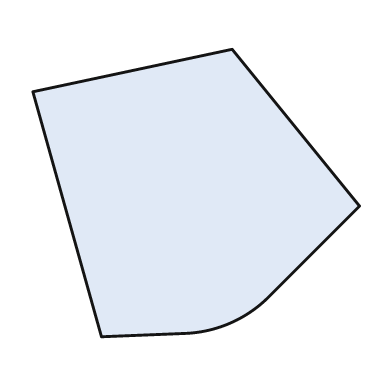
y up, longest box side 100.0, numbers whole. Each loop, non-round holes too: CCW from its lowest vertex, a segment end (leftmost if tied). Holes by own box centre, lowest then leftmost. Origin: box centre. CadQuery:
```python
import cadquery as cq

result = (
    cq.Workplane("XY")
    .moveTo(-29.0, -44.0)
    .lineTo(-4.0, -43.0)
    .threePointArc((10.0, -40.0), (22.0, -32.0))
    .lineTo(50.0, -4.0)
    .lineTo(11.0, 44.0)
    .lineTo(-50.0, 31.0)
    .close()
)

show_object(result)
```